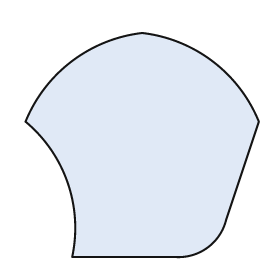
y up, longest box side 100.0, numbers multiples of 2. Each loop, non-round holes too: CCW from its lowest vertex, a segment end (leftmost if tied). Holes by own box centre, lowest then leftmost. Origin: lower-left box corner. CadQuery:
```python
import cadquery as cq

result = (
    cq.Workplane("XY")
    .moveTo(20.0, 0.0)
    .lineTo(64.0, 0.0)
    .threePointArc((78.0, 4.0), (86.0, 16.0))
    .lineTo(100.0, 58.0)
    .threePointArc((80.0, 84.0), (50.0, 96.0))
    .threePointArc((20.0, 84.0), (0.0, 58.0))
    .threePointArc((18.0, 32.0), (20.0, 0.0))
    .close()
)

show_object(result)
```